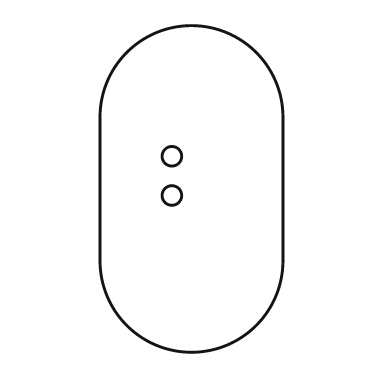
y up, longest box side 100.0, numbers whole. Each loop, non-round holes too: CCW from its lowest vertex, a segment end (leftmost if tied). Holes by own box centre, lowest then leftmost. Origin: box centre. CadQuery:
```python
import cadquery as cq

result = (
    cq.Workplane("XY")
    .moveTo(-28.0, -22.0)
    .threePointArc((0.0, -50.0), (28.0, -22.0))
    .lineTo(28.0, 22.0)
    .threePointArc((0.0, 50.0), (-28.0, 22.0))
    .close()
    .moveTo(-6.0, -2.0)
    .circle(3.0)
    .moveTo(-6.0, 10.0)
    .circle(3.0)
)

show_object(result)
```